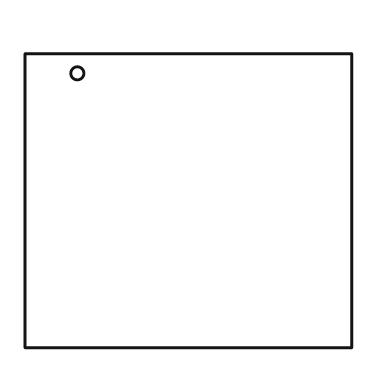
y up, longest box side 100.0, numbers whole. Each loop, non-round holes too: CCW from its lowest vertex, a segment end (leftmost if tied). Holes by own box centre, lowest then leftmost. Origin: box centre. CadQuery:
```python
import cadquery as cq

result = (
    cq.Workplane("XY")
    .moveTo(-50.0, -45.0)
    .lineTo(50.0, -45.0)
    .lineTo(50.0, 45.0)
    .lineTo(-50.0, 45.0)
    .close()
    .moveTo(-34.0, 39.0)
    .circle(2.0)
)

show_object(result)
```